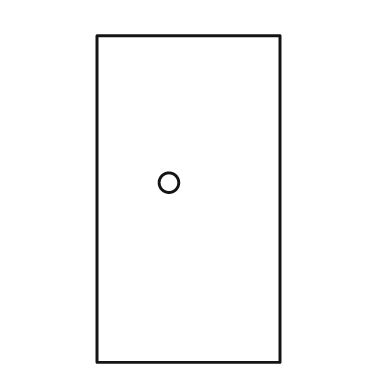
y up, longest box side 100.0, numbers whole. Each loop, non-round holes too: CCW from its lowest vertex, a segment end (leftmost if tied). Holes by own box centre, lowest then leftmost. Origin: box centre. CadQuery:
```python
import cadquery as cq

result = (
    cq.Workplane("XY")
    .moveTo(-28.0, -50.0)
    .lineTo(28.0, -50.0)
    .lineTo(28.0, 50.0)
    .lineTo(-28.0, 50.0)
    .close()
    .moveTo(-6.0, 5.0)
    .circle(3.0)
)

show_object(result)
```